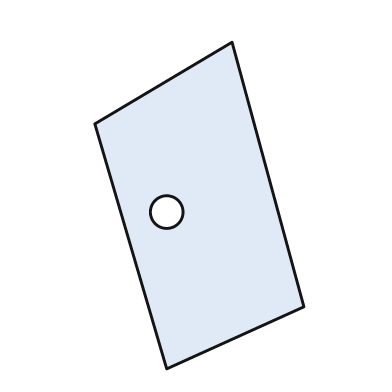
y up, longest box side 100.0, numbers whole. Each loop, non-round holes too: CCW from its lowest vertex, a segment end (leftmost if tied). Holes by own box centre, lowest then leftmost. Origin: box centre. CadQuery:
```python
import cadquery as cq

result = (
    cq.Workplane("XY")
    .moveTo(-10.0, -50.0)
    .lineTo(32.0, -31.0)
    .lineTo(10.0, 50.0)
    .lineTo(-32.0, 25.0)
    .close()
    .moveTo(-10.0, -2.0)
    .circle(5.0)
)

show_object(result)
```